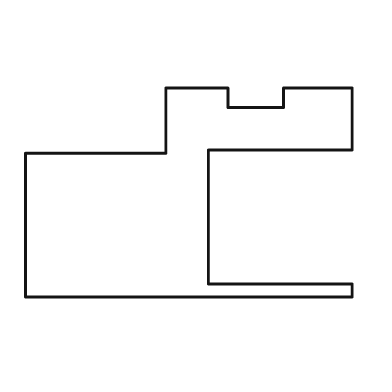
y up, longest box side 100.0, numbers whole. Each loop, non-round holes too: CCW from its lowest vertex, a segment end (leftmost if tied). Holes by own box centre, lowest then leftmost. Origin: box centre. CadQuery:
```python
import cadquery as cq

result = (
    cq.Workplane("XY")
    .moveTo(-50.0, -32.0)
    .lineTo(50.0, -32.0)
    .lineTo(50.0, -28.0)
    .lineTo(6.0, -28.0)
    .lineTo(6.0, 13.0)
    .lineTo(50.0, 13.0)
    .lineTo(50.0, 32.0)
    .lineTo(29.0, 32.0)
    .lineTo(29.0, 26.0)
    .lineTo(12.0, 26.0)
    .lineTo(12.0, 32.0)
    .lineTo(-7.0, 32.0)
    .lineTo(-7.0, 12.0)
    .lineTo(-50.0, 12.0)
    .close()
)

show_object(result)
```